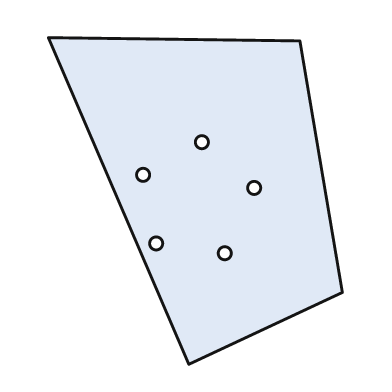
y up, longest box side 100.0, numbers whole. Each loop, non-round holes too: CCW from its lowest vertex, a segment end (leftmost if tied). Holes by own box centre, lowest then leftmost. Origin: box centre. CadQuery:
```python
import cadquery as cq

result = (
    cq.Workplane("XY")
    .moveTo(-2.0, -50.0)
    .lineTo(45.0, -28.0)
    .lineTo(32.0, 49.0)
    .lineTo(-45.0, 50.0)
    .close()
    .moveTo(9.0, -16.0)
    .circle(2.0)
    .moveTo(-12.0, -13.0)
    .circle(2.0)
    .moveTo(18.0, 4.0)
    .circle(2.0)
    .moveTo(-16.0, 8.0)
    .circle(2.0)
    .moveTo(2.0, 18.0)
    .circle(2.0)
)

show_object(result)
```